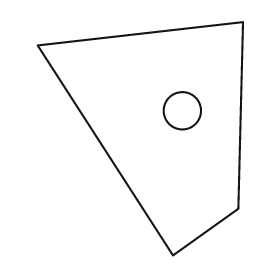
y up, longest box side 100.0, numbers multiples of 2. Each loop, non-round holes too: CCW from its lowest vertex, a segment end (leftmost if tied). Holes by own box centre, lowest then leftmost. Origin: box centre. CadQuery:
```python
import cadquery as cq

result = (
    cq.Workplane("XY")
    .moveTo(14.0, -50.0)
    .lineTo(42.0, -30.0)
    .lineTo(44.0, 50.0)
    .lineTo(-44.0, 40.0)
    .close()
    .moveTo(18.0, 12.0)
    .circle(8.0)
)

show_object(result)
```